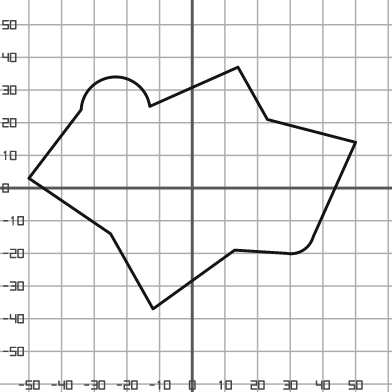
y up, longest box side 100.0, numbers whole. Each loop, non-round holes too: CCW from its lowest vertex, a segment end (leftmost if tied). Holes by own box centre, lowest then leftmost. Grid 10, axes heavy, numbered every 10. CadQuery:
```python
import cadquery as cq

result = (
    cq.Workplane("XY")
    .moveTo(-12.0, -37.0)
    .lineTo(13.0, -19.0)
    .lineTo(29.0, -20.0)
    .threePointArc((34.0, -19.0), (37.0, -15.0))
    .lineTo(50.0, 14.0)
    .lineTo(23.0, 21.0)
    .lineTo(14.0, 37.0)
    .lineTo(-13.0, 25.0)
    .threePointArc((-24.0, 34.0), (-34.0, 24.0))
    .lineTo(-50.0, 3.0)
    .lineTo(-25.0, -14.0)
    .close()
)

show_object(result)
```